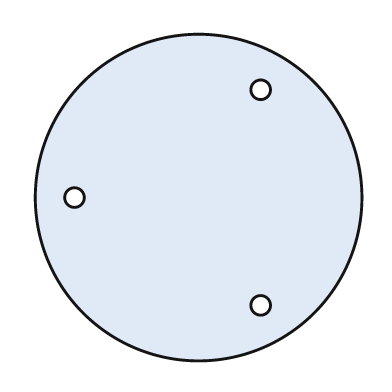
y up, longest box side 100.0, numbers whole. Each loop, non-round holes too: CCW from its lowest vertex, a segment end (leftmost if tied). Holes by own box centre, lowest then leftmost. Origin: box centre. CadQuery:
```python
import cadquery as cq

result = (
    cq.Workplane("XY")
    .moveTo(0.0, 0.0)
    .circle(50.0)
    .moveTo(19.0, -33.0)
    .circle(3.0)
    .moveTo(-38.0, 0.0)
    .circle(3.0)
    .moveTo(19.0, 33.0)
    .circle(3.0)
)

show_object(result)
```